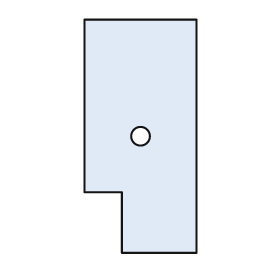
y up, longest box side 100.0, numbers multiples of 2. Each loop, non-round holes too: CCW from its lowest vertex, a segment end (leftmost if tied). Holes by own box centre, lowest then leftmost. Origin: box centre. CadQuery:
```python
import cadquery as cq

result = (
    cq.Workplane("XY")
    .moveTo(-8.0, -50.0)
    .lineTo(24.0, -50.0)
    .lineTo(24.0, 50.0)
    .lineTo(-24.0, 50.0)
    .lineTo(-24.0, -24.0)
    .lineTo(-8.0, -24.0)
    .close()
    .moveTo(0.0, 0.0)
    .circle(4.0)
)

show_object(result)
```